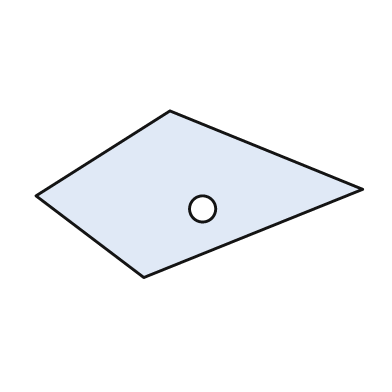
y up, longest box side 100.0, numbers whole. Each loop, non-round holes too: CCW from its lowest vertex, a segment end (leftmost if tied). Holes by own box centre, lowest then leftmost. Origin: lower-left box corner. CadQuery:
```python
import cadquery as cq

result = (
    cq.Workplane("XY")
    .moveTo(33.0, 0.0)
    .lineTo(100.0, 27.0)
    .lineTo(41.0, 51.0)
    .lineTo(0.0, 25.0)
    .close()
    .moveTo(51.0, 21.0)
    .circle(4.0)
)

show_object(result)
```